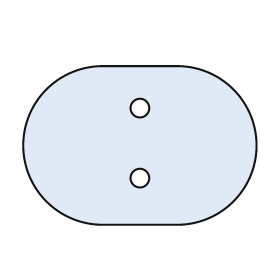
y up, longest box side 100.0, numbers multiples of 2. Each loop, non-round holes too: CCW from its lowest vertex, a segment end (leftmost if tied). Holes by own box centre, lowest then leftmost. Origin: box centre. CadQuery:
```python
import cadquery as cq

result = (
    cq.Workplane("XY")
    .moveTo(-16.0, -34.0)
    .lineTo(16.0, -34.0)
    .threePointArc((50.0, 0.0), (16.0, 34.0))
    .lineTo(-16.0, 34.0)
    .threePointArc((-50.0, 0.0), (-16.0, -34.0))
    .close()
    .moveTo(0.0, -14.0)
    .circle(4.0)
    .moveTo(0.0, 16.0)
    .circle(4.0)
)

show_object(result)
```